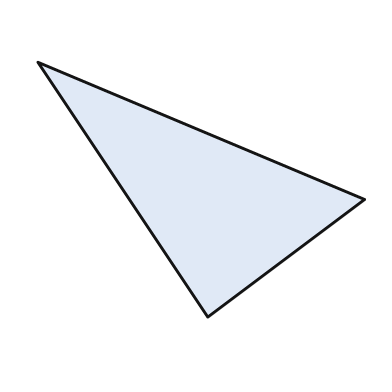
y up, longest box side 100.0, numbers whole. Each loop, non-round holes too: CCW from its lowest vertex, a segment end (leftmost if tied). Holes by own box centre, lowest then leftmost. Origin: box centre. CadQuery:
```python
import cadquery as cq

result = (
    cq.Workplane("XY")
    .moveTo(2.0, -39.0)
    .lineTo(50.0, -3.0)
    .lineTo(-50.0, 39.0)
    .close()
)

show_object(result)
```